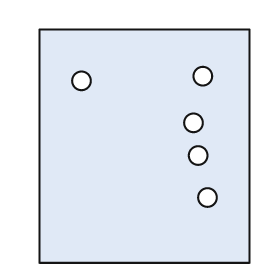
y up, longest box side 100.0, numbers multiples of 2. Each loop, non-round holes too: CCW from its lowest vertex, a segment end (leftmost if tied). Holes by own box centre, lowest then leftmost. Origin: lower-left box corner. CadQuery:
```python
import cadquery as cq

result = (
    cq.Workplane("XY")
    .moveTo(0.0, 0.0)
    .lineTo(90.0, 0.0)
    .lineTo(90.0, 100.0)
    .lineTo(0.0, 100.0)
    .close()
    .moveTo(72.0, 28.0)
    .circle(4.0)
    .moveTo(68.0, 46.0)
    .circle(4.0)
    .moveTo(66.0, 60.0)
    .circle(4.0)
    .moveTo(18.0, 78.0)
    .circle(4.0)
    .moveTo(70.0, 80.0)
    .circle(4.0)
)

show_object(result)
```